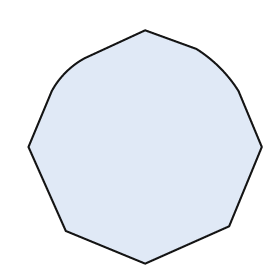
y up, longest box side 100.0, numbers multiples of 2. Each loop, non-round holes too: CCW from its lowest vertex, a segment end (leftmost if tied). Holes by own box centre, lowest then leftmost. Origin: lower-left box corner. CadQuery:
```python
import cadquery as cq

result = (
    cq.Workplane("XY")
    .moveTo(50.0, 0.0)
    .lineTo(86.0, 16.0)
    .lineTo(100.0, 50.0)
    .lineTo(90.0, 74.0)
    .threePointArc((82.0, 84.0), (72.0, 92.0))
    .lineTo(50.0, 100.0)
    .lineTo(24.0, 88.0)
    .threePointArc((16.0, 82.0), (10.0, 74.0))
    .lineTo(0.0, 50.0)
    .lineTo(16.0, 14.0)
    .close()
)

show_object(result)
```